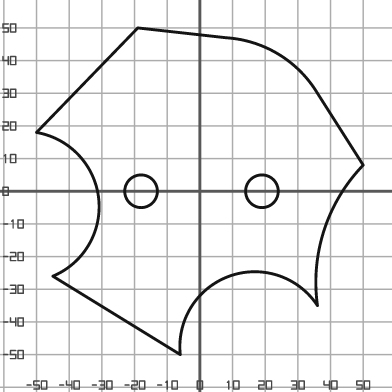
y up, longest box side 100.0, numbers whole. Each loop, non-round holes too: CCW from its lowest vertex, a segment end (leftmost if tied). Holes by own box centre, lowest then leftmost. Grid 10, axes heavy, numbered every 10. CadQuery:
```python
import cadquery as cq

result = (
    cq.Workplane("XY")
    .moveTo(-6.0, -50.0)
    .threePointArc((9.0, -26.0), (36.0, -35.0))
    .threePointArc((38.0, -12.0), (50.0, 8.0))
    .lineTo(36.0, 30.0)
    .threePointArc((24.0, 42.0), (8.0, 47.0))
    .lineTo(-19.0, 50.0)
    .lineTo(-50.0, 18.0)
    .threePointArc((-31.0, -2.0), (-45.0, -26.0))
    .close()
    .moveTo(-18.0, 0.0)
    .circle(5.0)
    .moveTo(19.0, 0.0)
    .circle(5.0)
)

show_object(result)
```